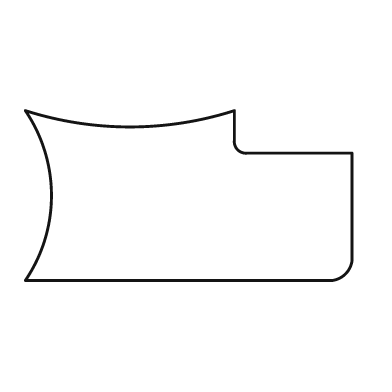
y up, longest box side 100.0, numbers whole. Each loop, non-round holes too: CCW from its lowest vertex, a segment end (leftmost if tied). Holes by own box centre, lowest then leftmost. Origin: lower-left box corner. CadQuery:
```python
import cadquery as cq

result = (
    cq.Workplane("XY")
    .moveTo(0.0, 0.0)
    .lineTo(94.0, 0.0)
    .threePointArc((98.0, 2.0), (100.0, 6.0))
    .lineTo(100.0, 39.0)
    .lineTo(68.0, 39.0)
    .threePointArc((65.0, 40.0), (64.0, 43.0))
    .lineTo(64.0, 52.0)
    .threePointArc((32.0, 47.0), (0.0, 52.0))
    .threePointArc((8.0, 26.0), (0.0, 0.0))
    .close()
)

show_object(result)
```